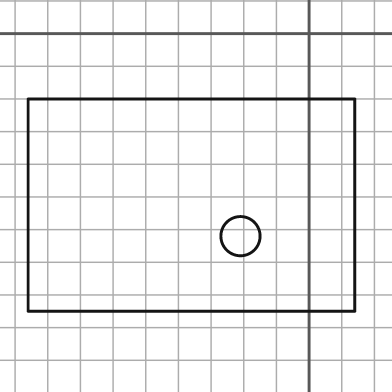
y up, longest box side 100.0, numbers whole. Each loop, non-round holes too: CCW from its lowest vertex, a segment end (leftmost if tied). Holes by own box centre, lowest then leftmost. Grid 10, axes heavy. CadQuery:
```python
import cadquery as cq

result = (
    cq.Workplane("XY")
    .moveTo(-86.0, -85.0)
    .lineTo(14.0, -85.0)
    .lineTo(14.0, -20.0)
    .lineTo(-86.0, -20.0)
    .close()
    .moveTo(-21.0, -62.0)
    .circle(6.0)
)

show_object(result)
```